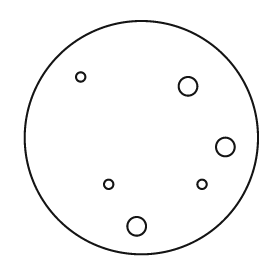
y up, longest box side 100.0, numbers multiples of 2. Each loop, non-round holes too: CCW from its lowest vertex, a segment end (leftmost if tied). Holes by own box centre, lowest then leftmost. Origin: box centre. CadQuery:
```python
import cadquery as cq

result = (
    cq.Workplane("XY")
    .moveTo(0.0, 0.0)
    .circle(50.0)
    .moveTo(-2.0, -38.0)
    .circle(4.0)
    .moveTo(-14.0, -20.0)
    .circle(2.0)
    .moveTo(26.0, -20.0)
    .circle(2.0)
    .moveTo(36.0, -4.0)
    .circle(4.0)
    .moveTo(20.0, 22.0)
    .circle(4.0)
    .moveTo(-26.0, 26.0)
    .circle(2.0)
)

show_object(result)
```